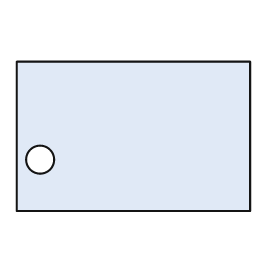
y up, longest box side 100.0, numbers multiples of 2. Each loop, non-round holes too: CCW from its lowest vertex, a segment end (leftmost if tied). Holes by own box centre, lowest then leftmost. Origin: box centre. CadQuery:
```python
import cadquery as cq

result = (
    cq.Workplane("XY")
    .moveTo(-50.0, -32.0)
    .lineTo(50.0, -32.0)
    .lineTo(50.0, 32.0)
    .lineTo(-50.0, 32.0)
    .close()
    .moveTo(-40.0, -10.0)
    .circle(6.0)
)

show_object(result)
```